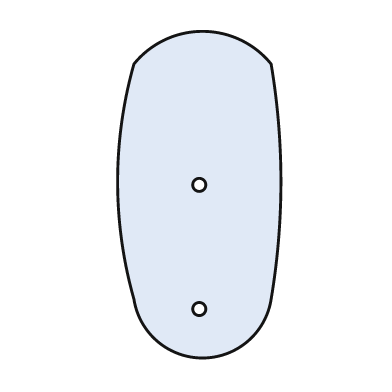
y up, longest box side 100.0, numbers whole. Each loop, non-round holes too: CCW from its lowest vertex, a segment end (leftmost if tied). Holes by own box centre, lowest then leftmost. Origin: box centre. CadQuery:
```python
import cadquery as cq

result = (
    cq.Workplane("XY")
    .moveTo(-20.0, -32.0)
    .threePointArc((1.0, -50.0), (22.0, -32.0))
    .threePointArc((25.0, 4.0), (22.0, 40.0))
    .threePointArc((1.0, 50.0), (-20.0, 40.0))
    .threePointArc((-25.0, 4.0), (-20.0, -32.0))
    .close()
    .moveTo(0.0, -35.0)
    .circle(2.0)
    .moveTo(0.0, 3.0)
    .circle(2.0)
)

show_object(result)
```